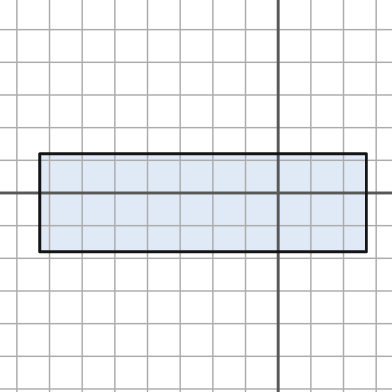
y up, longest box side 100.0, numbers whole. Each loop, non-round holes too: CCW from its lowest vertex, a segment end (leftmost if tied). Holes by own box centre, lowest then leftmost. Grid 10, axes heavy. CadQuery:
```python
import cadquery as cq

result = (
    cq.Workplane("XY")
    .moveTo(-73.0, -18.0)
    .lineTo(27.0, -18.0)
    .lineTo(27.0, 12.0)
    .lineTo(-73.0, 12.0)
    .close()
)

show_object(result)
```